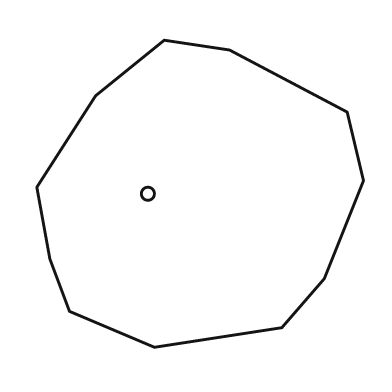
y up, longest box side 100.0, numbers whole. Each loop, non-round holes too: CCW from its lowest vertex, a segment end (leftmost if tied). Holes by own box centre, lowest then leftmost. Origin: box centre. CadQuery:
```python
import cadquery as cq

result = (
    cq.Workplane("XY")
    .moveTo(-14.0, -47.0)
    .lineTo(25.0, -41.0)
    .lineTo(38.0, -26.0)
    .lineTo(50.0, 4.0)
    .lineTo(45.0, 25.0)
    .lineTo(9.0, 44.0)
    .lineTo(-11.0, 47.0)
    .lineTo(-32.0, 30.0)
    .lineTo(-50.0, 2.0)
    .lineTo(-46.0, -20.0)
    .lineTo(-40.0, -36.0)
    .close()
    .moveTo(-16.0, 0.0)
    .circle(2.0)
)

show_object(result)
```